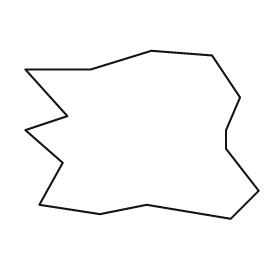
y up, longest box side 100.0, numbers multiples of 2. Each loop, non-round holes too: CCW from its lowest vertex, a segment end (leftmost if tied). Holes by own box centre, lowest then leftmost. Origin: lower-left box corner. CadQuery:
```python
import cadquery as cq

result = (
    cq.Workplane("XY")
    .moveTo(88.0, 0.0)
    .lineTo(100.0, 12.0)
    .lineTo(86.0, 30.0)
    .lineTo(86.0, 38.0)
    .lineTo(92.0, 52.0)
    .lineTo(80.0, 70.0)
    .lineTo(54.0, 72.0)
    .lineTo(28.0, 64.0)
    .lineTo(0.0, 64.0)
    .lineTo(18.0, 44.0)
    .lineTo(0.0, 38.0)
    .lineTo(16.0, 24.0)
    .lineTo(6.0, 6.0)
    .lineTo(32.0, 2.0)
    .lineTo(52.0, 6.0)
    .close()
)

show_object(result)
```